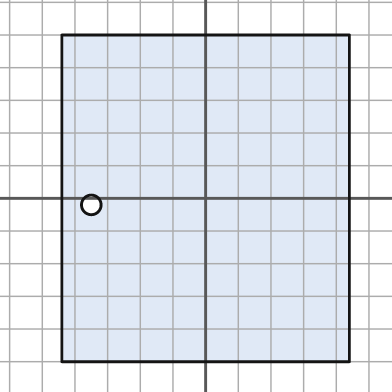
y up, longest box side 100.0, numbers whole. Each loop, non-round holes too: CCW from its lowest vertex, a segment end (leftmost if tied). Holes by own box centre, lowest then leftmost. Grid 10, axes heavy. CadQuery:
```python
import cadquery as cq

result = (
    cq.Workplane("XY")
    .moveTo(-44.0, -50.0)
    .lineTo(44.0, -50.0)
    .lineTo(44.0, 50.0)
    .lineTo(-44.0, 50.0)
    .close()
    .moveTo(-35.0, -2.0)
    .circle(3.0)
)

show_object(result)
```